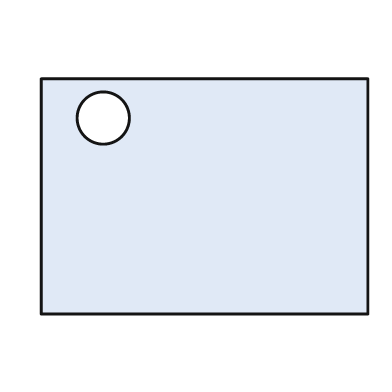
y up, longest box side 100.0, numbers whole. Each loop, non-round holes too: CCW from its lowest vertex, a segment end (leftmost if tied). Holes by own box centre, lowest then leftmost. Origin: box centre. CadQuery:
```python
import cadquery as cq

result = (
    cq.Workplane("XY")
    .moveTo(-50.0, -36.0)
    .lineTo(50.0, -36.0)
    .lineTo(50.0, 36.0)
    .lineTo(-50.0, 36.0)
    .close()
    .moveTo(-31.0, 24.0)
    .circle(8.0)
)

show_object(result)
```